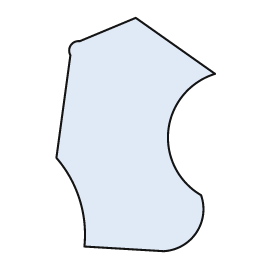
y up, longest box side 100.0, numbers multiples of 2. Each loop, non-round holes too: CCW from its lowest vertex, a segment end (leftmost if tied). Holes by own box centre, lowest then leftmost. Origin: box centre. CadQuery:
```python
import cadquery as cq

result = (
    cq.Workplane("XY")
    .moveTo(12.0, -50.0)
    .threePointArc((26.0, -42.0), (28.0, -26.0))
    .threePointArc((14.0, 2.0), (34.0, 26.0))
    .lineTo(0.0, 50.0)
    .lineTo(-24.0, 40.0)
    .threePointArc((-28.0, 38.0), (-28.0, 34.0))
    .lineTo(-34.0, -10.0)
    .threePointArc((-24.0, -28.0), (-22.0, -48.0))
    .close()
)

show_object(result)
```